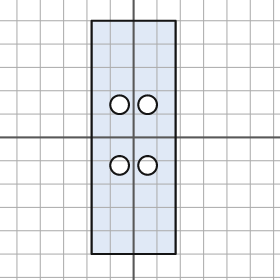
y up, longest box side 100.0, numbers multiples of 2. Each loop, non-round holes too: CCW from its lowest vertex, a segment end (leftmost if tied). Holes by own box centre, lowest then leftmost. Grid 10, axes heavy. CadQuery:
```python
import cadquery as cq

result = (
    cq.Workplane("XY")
    .moveTo(-18.0, -50.0)
    .lineTo(18.0, -50.0)
    .lineTo(18.0, 50.0)
    .lineTo(-18.0, 50.0)
    .close()
    .moveTo(-6.0, -12.0)
    .circle(4.0)
    .moveTo(6.0, -12.0)
    .circle(4.0)
    .moveTo(-6.0, 14.0)
    .circle(4.0)
    .moveTo(6.0, 14.0)
    .circle(4.0)
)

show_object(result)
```